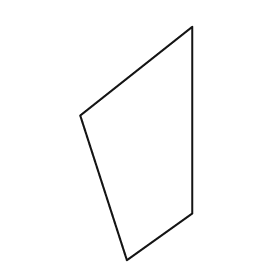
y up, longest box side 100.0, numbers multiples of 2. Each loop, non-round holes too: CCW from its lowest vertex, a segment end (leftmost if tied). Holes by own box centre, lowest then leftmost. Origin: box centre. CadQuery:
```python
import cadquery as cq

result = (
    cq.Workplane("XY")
    .moveTo(-4.0, -50.0)
    .lineTo(24.0, -30.0)
    .lineTo(24.0, 50.0)
    .lineTo(-24.0, 12.0)
    .close()
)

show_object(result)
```